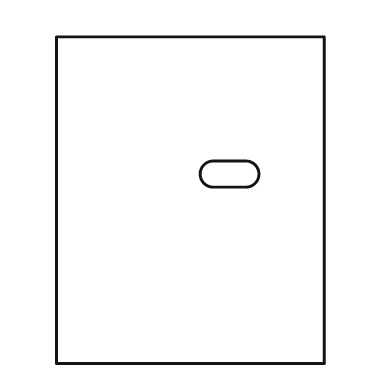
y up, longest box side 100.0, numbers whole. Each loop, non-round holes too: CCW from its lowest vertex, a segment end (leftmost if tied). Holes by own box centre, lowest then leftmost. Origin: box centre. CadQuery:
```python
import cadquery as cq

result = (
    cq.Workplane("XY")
    .moveTo(-41.0, -50.0)
    .lineTo(41.0, -50.0)
    .lineTo(41.0, 50.0)
    .lineTo(-41.0, 50.0)
    .close()
    .moveTo(7.0, 4.0)
    .lineTo(17.0, 4.0)
    .threePointArc((21.0, 8.0), (17.0, 12.0))
    .lineTo(7.0, 12.0)
    .threePointArc((3.0, 8.0), (7.0, 4.0))
    .close()
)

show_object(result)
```